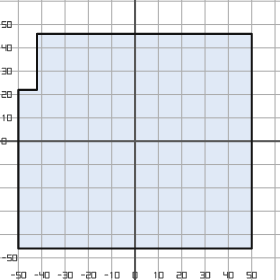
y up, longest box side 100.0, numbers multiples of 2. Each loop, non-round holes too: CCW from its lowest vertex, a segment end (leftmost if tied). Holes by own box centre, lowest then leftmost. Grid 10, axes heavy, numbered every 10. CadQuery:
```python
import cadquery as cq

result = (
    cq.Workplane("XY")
    .moveTo(-50.0, -46.0)
    .lineTo(50.0, -46.0)
    .lineTo(50.0, 46.0)
    .lineTo(-42.0, 46.0)
    .lineTo(-42.0, 22.0)
    .lineTo(-50.0, 22.0)
    .close()
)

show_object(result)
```